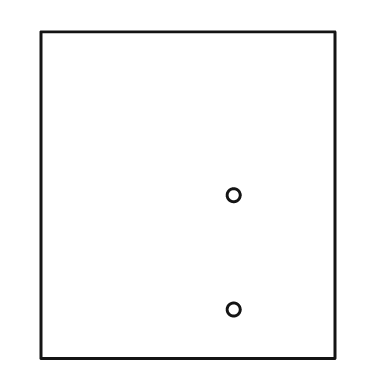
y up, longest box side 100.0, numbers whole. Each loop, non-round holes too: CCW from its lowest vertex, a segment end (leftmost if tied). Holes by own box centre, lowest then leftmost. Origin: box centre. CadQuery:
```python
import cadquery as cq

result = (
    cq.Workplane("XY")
    .moveTo(-45.0, -50.0)
    .lineTo(45.0, -50.0)
    .lineTo(45.0, 50.0)
    .lineTo(-45.0, 50.0)
    .close()
    .moveTo(14.0, -35.0)
    .circle(2.0)
    .moveTo(14.0, 0.0)
    .circle(2.0)
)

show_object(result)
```